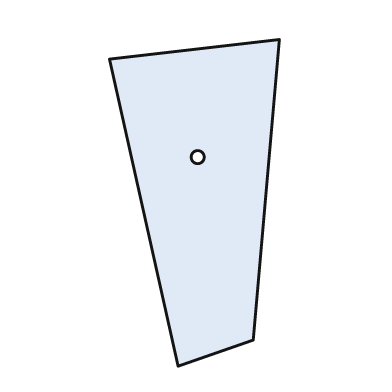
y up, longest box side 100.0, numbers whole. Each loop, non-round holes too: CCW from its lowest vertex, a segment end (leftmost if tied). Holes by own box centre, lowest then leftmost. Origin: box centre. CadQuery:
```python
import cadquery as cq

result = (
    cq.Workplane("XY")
    .moveTo(-5.0, -50.0)
    .lineTo(18.0, -42.0)
    .lineTo(26.0, 50.0)
    .lineTo(-26.0, 44.0)
    .close()
    .moveTo(1.0, 14.0)
    .circle(2.0)
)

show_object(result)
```